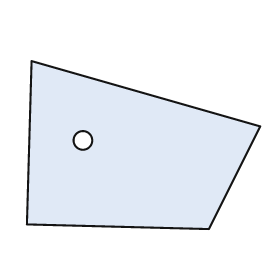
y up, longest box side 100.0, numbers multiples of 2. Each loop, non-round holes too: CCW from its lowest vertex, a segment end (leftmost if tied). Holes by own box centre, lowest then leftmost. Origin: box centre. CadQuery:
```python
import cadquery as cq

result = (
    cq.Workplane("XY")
    .moveTo(28.0, -36.0)
    .lineTo(50.0, 8.0)
    .lineTo(-48.0, 36.0)
    .lineTo(-50.0, -34.0)
    .close()
    .moveTo(-26.0, 2.0)
    .circle(4.0)
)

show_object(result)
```